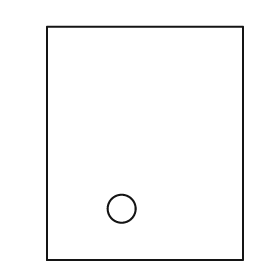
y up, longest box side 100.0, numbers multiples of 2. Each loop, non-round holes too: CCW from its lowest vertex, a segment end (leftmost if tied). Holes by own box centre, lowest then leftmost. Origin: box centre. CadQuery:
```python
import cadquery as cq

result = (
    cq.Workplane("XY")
    .moveTo(-42.0, -50.0)
    .lineTo(42.0, -50.0)
    .lineTo(42.0, 50.0)
    .lineTo(-42.0, 50.0)
    .close()
    .moveTo(-10.0, -28.0)
    .circle(6.0)
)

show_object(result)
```